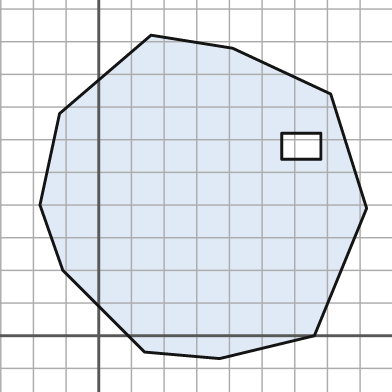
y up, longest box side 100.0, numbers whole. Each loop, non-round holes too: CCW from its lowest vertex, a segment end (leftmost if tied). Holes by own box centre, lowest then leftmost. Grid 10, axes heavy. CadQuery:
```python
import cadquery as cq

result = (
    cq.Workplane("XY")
    .moveTo(37.0, -7.0)
    .lineTo(66.0, 0.0)
    .lineTo(82.0, 39.0)
    .lineTo(71.0, 74.0)
    .lineTo(41.0, 88.0)
    .lineTo(16.0, 92.0)
    .lineTo(-12.0, 68.0)
    .lineTo(-18.0, 40.0)
    .lineTo(-11.0, 20.0)
    .lineTo(14.0, -5.0)
    .close()
    .moveTo(56.0, 54.0)
    .lineTo(68.0, 54.0)
    .lineTo(68.0, 62.0)
    .lineTo(56.0, 62.0)
    .close()
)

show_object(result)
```